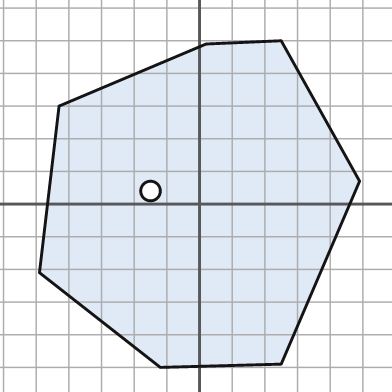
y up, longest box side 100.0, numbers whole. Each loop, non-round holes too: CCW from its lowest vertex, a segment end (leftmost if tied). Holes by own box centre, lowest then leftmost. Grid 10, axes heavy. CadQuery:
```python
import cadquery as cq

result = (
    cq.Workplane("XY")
    .moveTo(-12.0, -50.0)
    .lineTo(25.0, -49.0)
    .lineTo(49.0, 7.0)
    .lineTo(25.0, 50.0)
    .lineTo(2.0, 49.0)
    .lineTo(-43.0, 30.0)
    .lineTo(-49.0, -21.0)
    .close()
    .moveTo(-15.0, 4.0)
    .circle(3.0)
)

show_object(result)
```